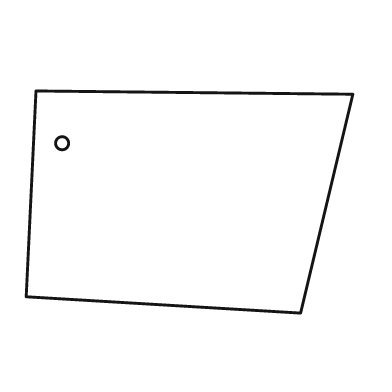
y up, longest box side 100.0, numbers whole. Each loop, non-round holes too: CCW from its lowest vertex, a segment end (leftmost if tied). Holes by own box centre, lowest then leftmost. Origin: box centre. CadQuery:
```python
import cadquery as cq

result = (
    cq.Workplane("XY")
    .moveTo(34.0, -34.0)
    .lineTo(50.0, 33.0)
    .lineTo(-47.0, 34.0)
    .lineTo(-50.0, -29.0)
    .close()
    .moveTo(-39.0, 18.0)
    .circle(2.0)
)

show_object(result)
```